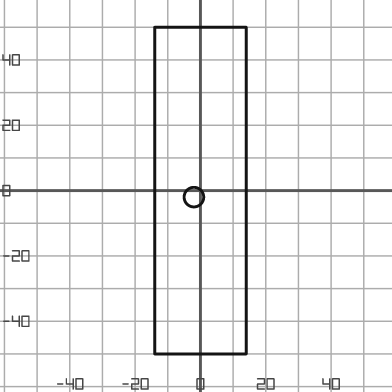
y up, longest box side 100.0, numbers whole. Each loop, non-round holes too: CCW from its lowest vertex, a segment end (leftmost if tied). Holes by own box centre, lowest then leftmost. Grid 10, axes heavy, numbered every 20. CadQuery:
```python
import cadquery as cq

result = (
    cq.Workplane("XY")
    .moveTo(-14.0, -50.0)
    .lineTo(14.0, -50.0)
    .lineTo(14.0, 50.0)
    .lineTo(-14.0, 50.0)
    .close()
    .moveTo(-2.0, -2.0)
    .circle(3.0)
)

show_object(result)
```